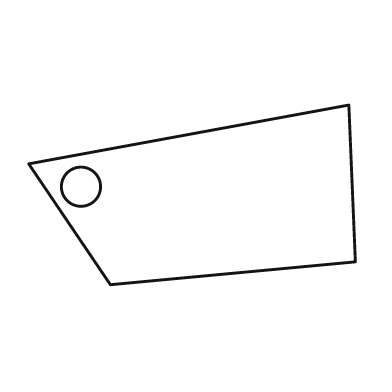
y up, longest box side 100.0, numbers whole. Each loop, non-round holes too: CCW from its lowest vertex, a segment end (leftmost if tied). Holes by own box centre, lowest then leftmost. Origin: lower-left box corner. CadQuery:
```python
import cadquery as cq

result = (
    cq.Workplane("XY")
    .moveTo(25.0, 0.0)
    .lineTo(100.0, 7.0)
    .lineTo(98.0, 55.0)
    .lineTo(0.0, 37.0)
    .close()
    .moveTo(16.0, 30.0)
    .circle(6.0)
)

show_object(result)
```